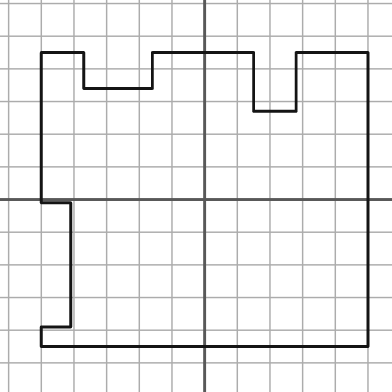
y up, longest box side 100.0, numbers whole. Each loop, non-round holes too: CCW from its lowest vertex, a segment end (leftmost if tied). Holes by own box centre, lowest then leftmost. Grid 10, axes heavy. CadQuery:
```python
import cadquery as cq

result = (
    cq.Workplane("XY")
    .moveTo(-50.0, -45.0)
    .lineTo(50.0, -45.0)
    .lineTo(50.0, 45.0)
    .lineTo(28.0, 45.0)
    .lineTo(28.0, 27.0)
    .lineTo(15.0, 27.0)
    .lineTo(15.0, 45.0)
    .lineTo(-16.0, 45.0)
    .lineTo(-16.0, 34.0)
    .lineTo(-37.0, 34.0)
    .lineTo(-37.0, 45.0)
    .lineTo(-50.0, 45.0)
    .lineTo(-50.0, -1.0)
    .lineTo(-41.0, -1.0)
    .lineTo(-41.0, -39.0)
    .lineTo(-50.0, -39.0)
    .close()
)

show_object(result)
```